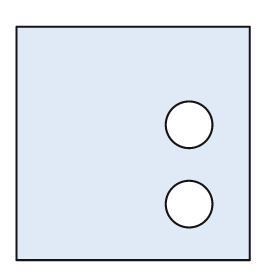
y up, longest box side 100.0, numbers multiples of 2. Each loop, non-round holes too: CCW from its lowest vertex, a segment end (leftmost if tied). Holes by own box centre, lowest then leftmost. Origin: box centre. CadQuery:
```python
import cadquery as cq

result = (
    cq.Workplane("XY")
    .moveTo(-50.0, -50.0)
    .lineTo(50.0, -50.0)
    .lineTo(50.0, 50.0)
    .lineTo(-50.0, 50.0)
    .close()
    .moveTo(24.0, -26.0)
    .circle(10.0)
    .moveTo(24.0, 8.0)
    .circle(10.0)
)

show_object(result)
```